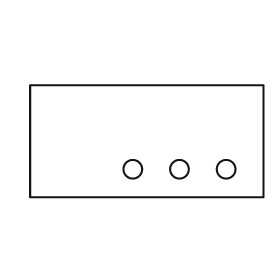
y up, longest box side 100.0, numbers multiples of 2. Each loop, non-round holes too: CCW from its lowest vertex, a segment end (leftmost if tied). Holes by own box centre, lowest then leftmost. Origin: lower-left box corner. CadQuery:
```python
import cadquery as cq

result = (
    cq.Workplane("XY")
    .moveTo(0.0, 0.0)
    .lineTo(100.0, 0.0)
    .lineTo(100.0, 48.0)
    .lineTo(0.0, 48.0)
    .close()
    .moveTo(44.0, 12.0)
    .circle(4.0)
    .moveTo(64.0, 12.0)
    .circle(4.0)
    .moveTo(84.0, 12.0)
    .circle(4.0)
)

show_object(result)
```